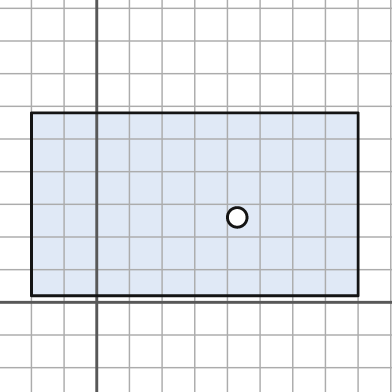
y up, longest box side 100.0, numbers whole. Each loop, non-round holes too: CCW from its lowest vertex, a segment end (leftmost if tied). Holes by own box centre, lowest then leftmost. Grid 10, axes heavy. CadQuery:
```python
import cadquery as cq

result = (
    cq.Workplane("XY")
    .moveTo(-20.0, 2.0)
    .lineTo(80.0, 2.0)
    .lineTo(80.0, 58.0)
    .lineTo(-20.0, 58.0)
    .close()
    .moveTo(43.0, 26.0)
    .circle(3.0)
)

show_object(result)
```